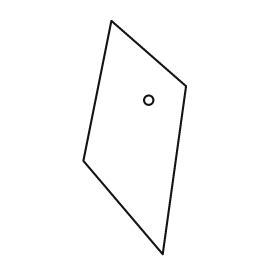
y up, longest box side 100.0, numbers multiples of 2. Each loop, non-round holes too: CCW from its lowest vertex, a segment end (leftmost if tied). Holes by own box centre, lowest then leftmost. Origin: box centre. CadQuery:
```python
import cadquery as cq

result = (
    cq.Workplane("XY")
    .moveTo(12.0, -50.0)
    .lineTo(22.0, 22.0)
    .lineTo(-10.0, 50.0)
    .lineTo(-22.0, -10.0)
    .close()
    .moveTo(6.0, 16.0)
    .circle(2.0)
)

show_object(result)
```